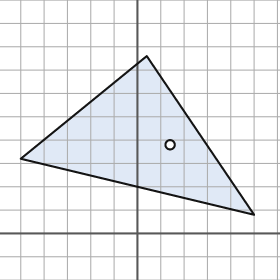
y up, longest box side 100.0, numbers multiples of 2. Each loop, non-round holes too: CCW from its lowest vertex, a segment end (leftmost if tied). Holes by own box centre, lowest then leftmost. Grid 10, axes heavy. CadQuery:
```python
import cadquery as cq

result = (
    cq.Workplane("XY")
    .moveTo(50.0, 8.0)
    .lineTo(4.0, 76.0)
    .lineTo(-50.0, 32.0)
    .close()
    .moveTo(14.0, 38.0)
    .circle(2.0)
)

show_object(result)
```